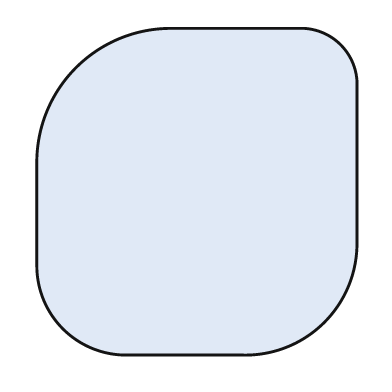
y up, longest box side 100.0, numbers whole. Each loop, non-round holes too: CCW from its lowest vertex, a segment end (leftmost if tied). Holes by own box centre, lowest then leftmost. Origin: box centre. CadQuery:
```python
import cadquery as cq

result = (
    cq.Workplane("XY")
    .moveTo(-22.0, -50.0)
    .lineTo(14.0, -50.0)
    .threePointArc((39.0, -40.0), (49.0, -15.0))
    .lineTo(49.0, 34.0)
    .threePointArc((44.0, 45.0), (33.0, 50.0))
    .lineTo(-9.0, 50.0)
    .threePointArc((-37.0, 38.0), (-49.0, 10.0))
    .lineTo(-49.0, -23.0)
    .threePointArc((-41.0, -42.0), (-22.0, -50.0))
    .close()
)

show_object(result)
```